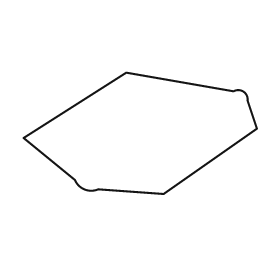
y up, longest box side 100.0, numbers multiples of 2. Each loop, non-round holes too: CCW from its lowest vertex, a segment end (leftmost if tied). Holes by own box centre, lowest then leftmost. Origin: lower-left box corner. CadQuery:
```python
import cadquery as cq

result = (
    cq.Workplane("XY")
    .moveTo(60.0, 0.0)
    .lineTo(100.0, 28.0)
    .lineTo(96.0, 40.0)
    .threePointArc((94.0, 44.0), (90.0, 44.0))
    .lineTo(44.0, 52.0)
    .lineTo(0.0, 24.0)
    .lineTo(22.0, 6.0)
    .threePointArc((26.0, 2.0), (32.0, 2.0))
    .close()
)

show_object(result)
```